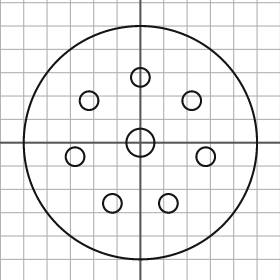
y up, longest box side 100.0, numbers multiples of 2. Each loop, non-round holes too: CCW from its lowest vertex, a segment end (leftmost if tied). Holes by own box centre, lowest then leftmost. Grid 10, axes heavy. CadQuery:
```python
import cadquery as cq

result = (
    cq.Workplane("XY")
    .moveTo(0.0, 0.0)
    .circle(50.0)
    .moveTo(-12.0, -26.0)
    .circle(4.0)
    .moveTo(12.0, -26.0)
    .circle(4.0)
    .moveTo(-28.0, -6.0)
    .circle(4.0)
    .moveTo(28.0, -6.0)
    .circle(4.0)
    .moveTo(0.0, 0.0)
    .circle(6.0)
    .moveTo(-22.0, 18.0)
    .circle(4.0)
    .moveTo(22.0, 18.0)
    .circle(4.0)
    .moveTo(0.0, 28.0)
    .circle(4.0)
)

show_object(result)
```